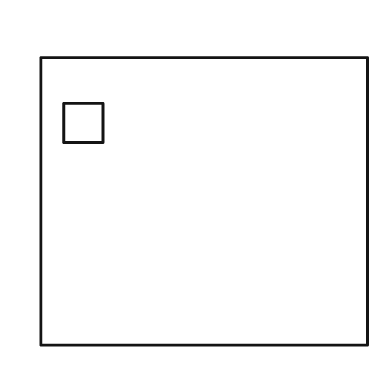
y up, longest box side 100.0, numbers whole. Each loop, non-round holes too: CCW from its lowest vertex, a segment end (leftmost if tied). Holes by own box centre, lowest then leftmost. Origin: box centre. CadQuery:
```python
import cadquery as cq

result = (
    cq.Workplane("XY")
    .moveTo(-50.0, -44.0)
    .lineTo(50.0, -44.0)
    .lineTo(50.0, 44.0)
    .lineTo(-50.0, 44.0)
    .close()
    .moveTo(-43.0, 18.0)
    .lineTo(-31.0, 18.0)
    .lineTo(-31.0, 30.0)
    .lineTo(-43.0, 30.0)
    .close()
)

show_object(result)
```